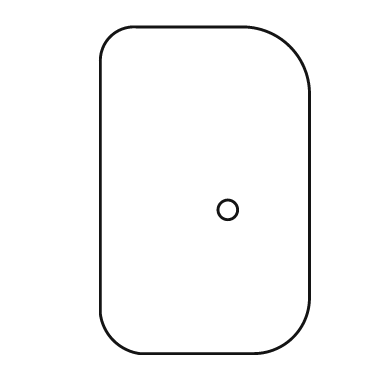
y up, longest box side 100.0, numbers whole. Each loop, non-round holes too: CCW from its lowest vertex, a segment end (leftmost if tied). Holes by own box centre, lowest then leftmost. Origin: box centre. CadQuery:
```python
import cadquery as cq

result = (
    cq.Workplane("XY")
    .moveTo(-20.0, -50.0)
    .lineTo(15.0, -50.0)
    .threePointArc((27.0, -45.0), (32.0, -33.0))
    .lineTo(32.0, 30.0)
    .threePointArc((26.0, 44.0), (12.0, 50.0))
    .lineTo(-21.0, 50.0)
    .threePointArc((-29.0, 47.0), (-32.0, 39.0))
    .lineTo(-32.0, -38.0)
    .threePointArc((-28.0, -46.0), (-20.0, -50.0))
    .close()
    .moveTo(7.0, -6.0)
    .circle(3.0)
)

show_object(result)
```